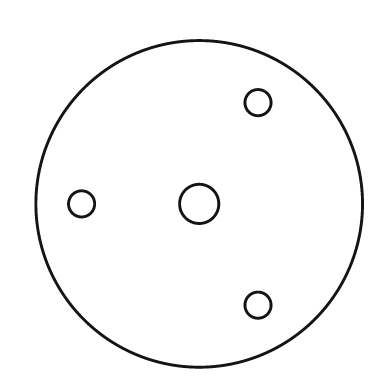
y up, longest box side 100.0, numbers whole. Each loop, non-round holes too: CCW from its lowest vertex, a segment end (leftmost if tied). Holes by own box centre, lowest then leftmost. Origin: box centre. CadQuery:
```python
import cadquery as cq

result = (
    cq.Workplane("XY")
    .moveTo(0.0, 0.0)
    .circle(50.0)
    .moveTo(18.0, -31.0)
    .circle(4.0)
    .moveTo(-36.0, 0.0)
    .circle(4.0)
    .moveTo(0.0, 0.0)
    .circle(6.0)
    .moveTo(18.0, 31.0)
    .circle(4.0)
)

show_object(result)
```